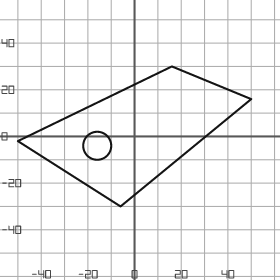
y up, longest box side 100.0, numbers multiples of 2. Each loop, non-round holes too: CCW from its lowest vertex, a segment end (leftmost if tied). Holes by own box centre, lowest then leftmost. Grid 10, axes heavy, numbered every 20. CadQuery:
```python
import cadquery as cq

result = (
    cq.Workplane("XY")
    .moveTo(-6.0, -30.0)
    .lineTo(50.0, 16.0)
    .lineTo(16.0, 30.0)
    .lineTo(-50.0, -2.0)
    .close()
    .moveTo(-16.0, -4.0)
    .circle(6.0)
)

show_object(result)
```